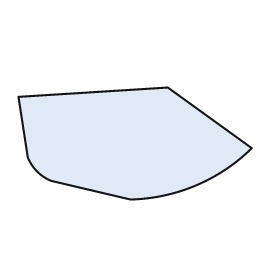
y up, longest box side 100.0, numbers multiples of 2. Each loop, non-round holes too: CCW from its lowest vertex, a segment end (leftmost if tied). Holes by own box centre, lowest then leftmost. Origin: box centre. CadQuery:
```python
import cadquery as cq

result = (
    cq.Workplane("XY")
    .moveTo(-2.0, -24.0)
    .threePointArc((26.0, -18.0), (50.0, -2.0))
    .lineTo(14.0, 24.0)
    .lineTo(-50.0, 20.0)
    .lineTo(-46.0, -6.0)
    .threePointArc((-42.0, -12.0), (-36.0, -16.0))
    .close()
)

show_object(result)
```